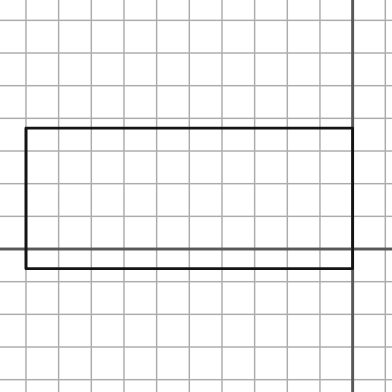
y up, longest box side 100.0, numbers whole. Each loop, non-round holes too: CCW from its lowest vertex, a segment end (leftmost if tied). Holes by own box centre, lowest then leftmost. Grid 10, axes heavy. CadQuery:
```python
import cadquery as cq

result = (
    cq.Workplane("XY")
    .moveTo(-100.0, -6.0)
    .lineTo(0.0, -6.0)
    .lineTo(0.0, 37.0)
    .lineTo(-100.0, 37.0)
    .close()
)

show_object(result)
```